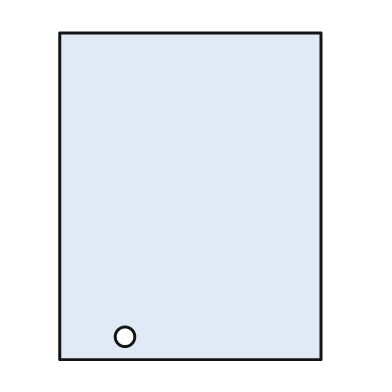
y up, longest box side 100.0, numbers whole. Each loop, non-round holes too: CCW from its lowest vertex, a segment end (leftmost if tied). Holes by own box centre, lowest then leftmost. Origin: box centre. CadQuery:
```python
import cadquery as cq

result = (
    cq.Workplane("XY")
    .moveTo(-40.0, -50.0)
    .lineTo(40.0, -50.0)
    .lineTo(40.0, 50.0)
    .lineTo(-40.0, 50.0)
    .close()
    .moveTo(-20.0, -43.0)
    .circle(3.0)
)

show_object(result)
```